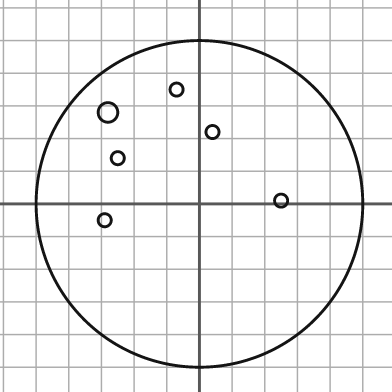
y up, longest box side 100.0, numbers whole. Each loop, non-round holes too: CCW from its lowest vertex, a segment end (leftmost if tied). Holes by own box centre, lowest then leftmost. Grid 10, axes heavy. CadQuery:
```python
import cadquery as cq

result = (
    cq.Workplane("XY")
    .moveTo(0.0, 0.0)
    .circle(50.0)
    .moveTo(-29.0, -5.0)
    .circle(2.0)
    .moveTo(25.0, 1.0)
    .circle(2.0)
    .moveTo(-25.0, 14.0)
    .circle(2.0)
    .moveTo(4.0, 22.0)
    .circle(2.0)
    .moveTo(-28.0, 28.0)
    .circle(3.0)
    .moveTo(-7.0, 35.0)
    .circle(2.0)
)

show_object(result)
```